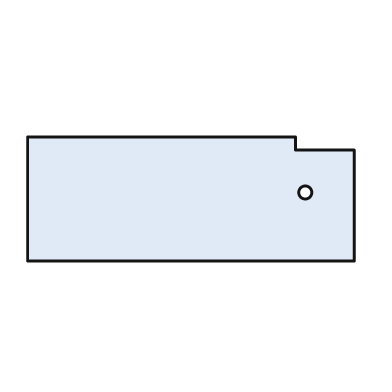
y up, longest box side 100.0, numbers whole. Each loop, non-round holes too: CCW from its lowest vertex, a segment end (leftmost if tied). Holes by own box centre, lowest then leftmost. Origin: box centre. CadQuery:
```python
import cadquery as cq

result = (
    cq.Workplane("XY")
    .moveTo(-50.0, -19.0)
    .lineTo(50.0, -19.0)
    .lineTo(50.0, 15.0)
    .lineTo(32.0, 15.0)
    .lineTo(32.0, 19.0)
    .lineTo(-50.0, 19.0)
    .close()
    .moveTo(35.0, 2.0)
    .circle(2.0)
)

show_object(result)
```